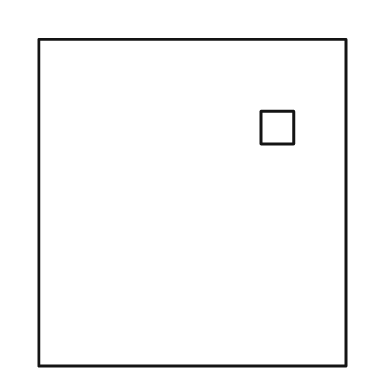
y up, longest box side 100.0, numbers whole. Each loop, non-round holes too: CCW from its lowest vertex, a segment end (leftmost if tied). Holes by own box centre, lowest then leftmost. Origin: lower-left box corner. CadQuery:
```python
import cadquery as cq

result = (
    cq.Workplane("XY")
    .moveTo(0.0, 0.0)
    .lineTo(94.0, 0.0)
    .lineTo(94.0, 100.0)
    .lineTo(0.0, 100.0)
    .close()
    .moveTo(68.0, 68.0)
    .lineTo(78.0, 68.0)
    .lineTo(78.0, 78.0)
    .lineTo(68.0, 78.0)
    .close()
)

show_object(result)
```